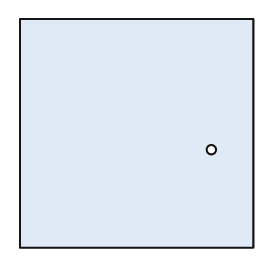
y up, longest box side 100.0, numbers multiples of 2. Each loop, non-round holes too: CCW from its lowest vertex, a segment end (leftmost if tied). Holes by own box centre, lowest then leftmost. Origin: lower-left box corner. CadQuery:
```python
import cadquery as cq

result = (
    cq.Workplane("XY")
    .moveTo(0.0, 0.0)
    .lineTo(100.0, 0.0)
    .lineTo(100.0, 98.0)
    .lineTo(0.0, 98.0)
    .close()
    .moveTo(82.0, 42.0)
    .circle(2.0)
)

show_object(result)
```